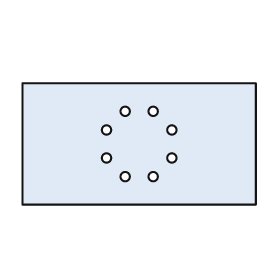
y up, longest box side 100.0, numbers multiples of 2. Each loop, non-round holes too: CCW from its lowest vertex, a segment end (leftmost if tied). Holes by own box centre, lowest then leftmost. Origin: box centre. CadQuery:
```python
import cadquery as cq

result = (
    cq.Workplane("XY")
    .moveTo(-50.0, -26.0)
    .lineTo(50.0, -26.0)
    .lineTo(50.0, 26.0)
    .lineTo(-50.0, 26.0)
    .close()
    .moveTo(-6.0, -14.0)
    .circle(2.0)
    .moveTo(6.0, -14.0)
    .circle(2.0)
    .moveTo(-14.0, -6.0)
    .circle(2.0)
    .moveTo(14.0, -6.0)
    .circle(2.0)
    .moveTo(-14.0, 6.0)
    .circle(2.0)
    .moveTo(14.0, 6.0)
    .circle(2.0)
    .moveTo(-6.0, 14.0)
    .circle(2.0)
    .moveTo(6.0, 14.0)
    .circle(2.0)
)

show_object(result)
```